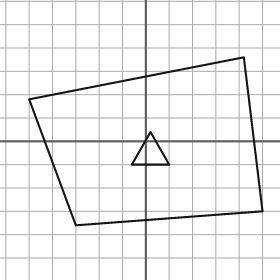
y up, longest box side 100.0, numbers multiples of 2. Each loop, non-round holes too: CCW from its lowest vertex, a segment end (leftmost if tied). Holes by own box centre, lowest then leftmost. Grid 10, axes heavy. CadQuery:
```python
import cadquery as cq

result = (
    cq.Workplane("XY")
    .moveTo(-30.0, -36.0)
    .lineTo(50.0, -30.0)
    .lineTo(42.0, 36.0)
    .lineTo(-50.0, 18.0)
    .close()
    .moveTo(-6.0, -10.0)
    .lineTo(10.0, -10.0)
    .lineTo(2.0, 4.0)
    .close()
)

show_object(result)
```